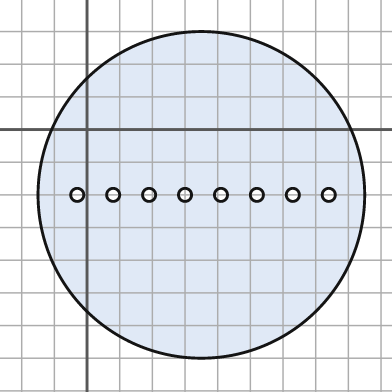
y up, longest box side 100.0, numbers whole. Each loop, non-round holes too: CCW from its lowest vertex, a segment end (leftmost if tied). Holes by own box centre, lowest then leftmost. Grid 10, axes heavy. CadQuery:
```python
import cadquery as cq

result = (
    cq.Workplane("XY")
    .moveTo(35.0, -20.0)
    .circle(50.0)
    .moveTo(-3.0, -20.0)
    .circle(2.0)
    .moveTo(8.0, -20.0)
    .circle(2.0)
    .moveTo(19.0, -20.0)
    .circle(2.0)
    .moveTo(30.0, -20.0)
    .circle(2.0)
    .moveTo(41.0, -20.0)
    .circle(2.0)
    .moveTo(52.0, -20.0)
    .circle(2.0)
    .moveTo(63.0, -20.0)
    .circle(2.0)
    .moveTo(74.0, -20.0)
    .circle(2.0)
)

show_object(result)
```